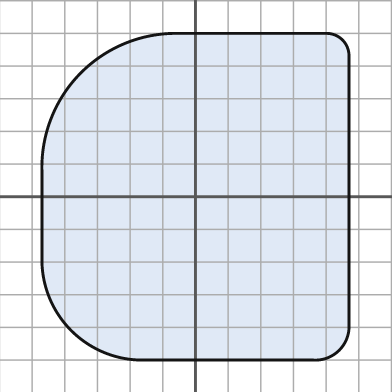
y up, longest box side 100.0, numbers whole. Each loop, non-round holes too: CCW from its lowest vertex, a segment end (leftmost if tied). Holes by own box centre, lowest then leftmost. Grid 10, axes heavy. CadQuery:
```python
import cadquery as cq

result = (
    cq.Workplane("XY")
    .moveTo(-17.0, -50.0)
    .lineTo(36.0, -50.0)
    .threePointArc((44.0, -47.0), (47.0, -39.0))
    .lineTo(47.0, 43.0)
    .threePointArc((45.0, 48.0), (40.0, 50.0))
    .lineTo(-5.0, 50.0)
    .threePointArc((-35.0, 38.0), (-47.0, 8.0))
    .lineTo(-47.0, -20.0)
    .threePointArc((-38.0, -41.0), (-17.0, -50.0))
    .close()
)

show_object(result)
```